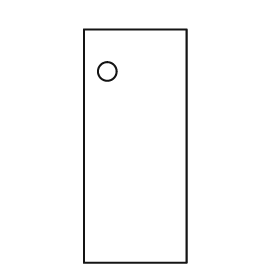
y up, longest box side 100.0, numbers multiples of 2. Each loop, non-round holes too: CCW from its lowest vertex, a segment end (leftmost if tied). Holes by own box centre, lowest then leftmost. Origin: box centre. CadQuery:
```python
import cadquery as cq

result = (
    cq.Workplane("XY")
    .moveTo(-22.0, -50.0)
    .lineTo(22.0, -50.0)
    .lineTo(22.0, 50.0)
    .lineTo(-22.0, 50.0)
    .close()
    .moveTo(-12.0, 32.0)
    .circle(4.0)
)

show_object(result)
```